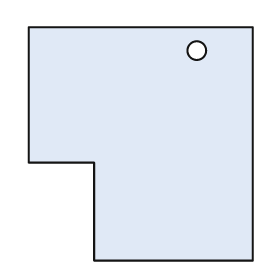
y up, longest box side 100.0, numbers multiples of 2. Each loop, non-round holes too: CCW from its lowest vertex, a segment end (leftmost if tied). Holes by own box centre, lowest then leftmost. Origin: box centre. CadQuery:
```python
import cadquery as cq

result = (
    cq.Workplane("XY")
    .moveTo(-20.0, -50.0)
    .lineTo(48.0, -50.0)
    .lineTo(48.0, 50.0)
    .lineTo(-48.0, 50.0)
    .lineTo(-48.0, -8.0)
    .lineTo(-20.0, -8.0)
    .close()
    .moveTo(24.0, 40.0)
    .circle(4.0)
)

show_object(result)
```